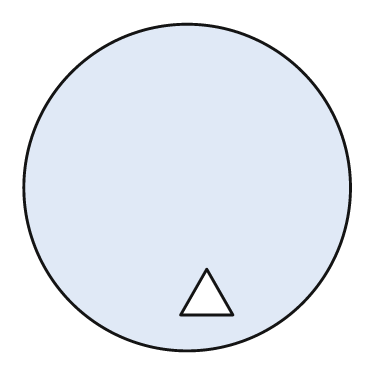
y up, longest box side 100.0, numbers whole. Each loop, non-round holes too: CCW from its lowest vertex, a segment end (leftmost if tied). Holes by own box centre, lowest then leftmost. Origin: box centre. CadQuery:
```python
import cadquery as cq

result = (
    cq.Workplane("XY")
    .moveTo(0.0, 0.0)
    .circle(50.0)
    .moveTo(-2.0, -39.0)
    .lineTo(14.0, -39.0)
    .lineTo(6.0, -25.0)
    .close()
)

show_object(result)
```